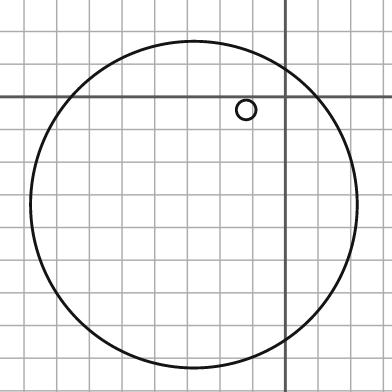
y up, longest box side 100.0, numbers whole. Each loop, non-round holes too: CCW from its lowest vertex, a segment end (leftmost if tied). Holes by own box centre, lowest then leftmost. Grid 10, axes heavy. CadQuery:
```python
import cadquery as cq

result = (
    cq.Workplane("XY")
    .moveTo(-28.0, -33.0)
    .circle(50.0)
    .moveTo(-12.0, -4.0)
    .circle(3.0)
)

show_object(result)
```